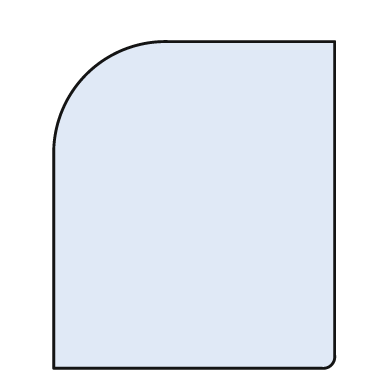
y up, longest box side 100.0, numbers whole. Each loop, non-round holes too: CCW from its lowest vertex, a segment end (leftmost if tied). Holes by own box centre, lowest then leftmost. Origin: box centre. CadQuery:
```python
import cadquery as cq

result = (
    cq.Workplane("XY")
    .moveTo(-43.0, -50.0)
    .lineTo(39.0, -50.0)
    .threePointArc((42.0, -49.0), (43.0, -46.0))
    .lineTo(43.0, 50.0)
    .lineTo(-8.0, 50.0)
    .threePointArc((-33.0, 40.0), (-43.0, 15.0))
    .close()
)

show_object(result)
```